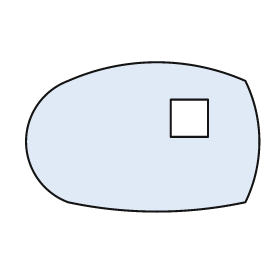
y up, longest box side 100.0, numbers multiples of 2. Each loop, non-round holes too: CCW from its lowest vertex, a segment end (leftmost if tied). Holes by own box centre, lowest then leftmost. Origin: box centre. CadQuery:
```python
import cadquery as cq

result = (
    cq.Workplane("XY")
    .moveTo(-32.0, -28.0)
    .threePointArc((6.0, -32.0), (44.0, -28.0))
    .threePointArc((50.0, -2.0), (44.0, 24.0))
    .threePointArc((6.0, 32.0), (-32.0, 24.0))
    .threePointArc((-50.0, -2.0), (-32.0, -28.0))
    .close()
    .moveTo(12.0, 0.0)
    .lineTo(28.0, 0.0)
    .lineTo(28.0, 16.0)
    .lineTo(12.0, 16.0)
    .close()
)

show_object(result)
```